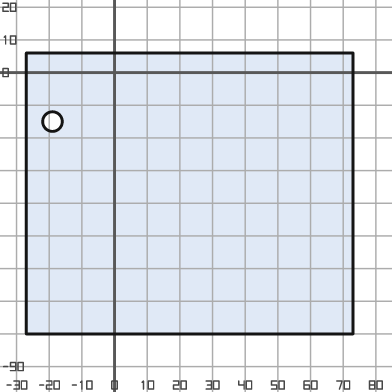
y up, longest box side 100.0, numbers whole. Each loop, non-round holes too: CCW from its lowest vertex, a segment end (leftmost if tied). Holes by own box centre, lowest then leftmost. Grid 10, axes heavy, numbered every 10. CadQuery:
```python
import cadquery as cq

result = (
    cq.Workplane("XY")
    .moveTo(-27.0, -80.0)
    .lineTo(73.0, -80.0)
    .lineTo(73.0, 6.0)
    .lineTo(-27.0, 6.0)
    .close()
    .moveTo(-19.0, -15.0)
    .circle(3.0)
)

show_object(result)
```